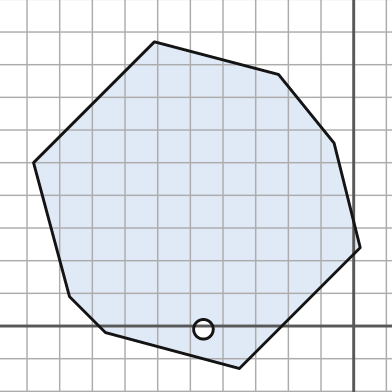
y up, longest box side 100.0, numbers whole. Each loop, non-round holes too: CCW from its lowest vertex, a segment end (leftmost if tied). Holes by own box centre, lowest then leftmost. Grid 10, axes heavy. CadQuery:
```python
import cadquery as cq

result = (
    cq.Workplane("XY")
    .moveTo(-35.0, -13.0)
    .lineTo(2.0, 24.0)
    .lineTo(-6.0, 56.0)
    .lineTo(-23.0, 77.0)
    .lineTo(-61.0, 87.0)
    .lineTo(-98.0, 50.0)
    .lineTo(-87.0, 9.0)
    .lineTo(-76.0, -2.0)
    .close()
    .moveTo(-46.0, -1.0)
    .circle(3.0)
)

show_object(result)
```